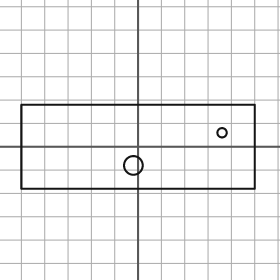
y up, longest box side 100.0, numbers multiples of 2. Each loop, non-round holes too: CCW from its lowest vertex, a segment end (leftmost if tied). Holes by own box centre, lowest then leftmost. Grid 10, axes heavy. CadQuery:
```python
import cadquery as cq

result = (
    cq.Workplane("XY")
    .moveTo(-50.0, -18.0)
    .lineTo(50.0, -18.0)
    .lineTo(50.0, 18.0)
    .lineTo(-50.0, 18.0)
    .close()
    .moveTo(-2.0, -8.0)
    .circle(4.0)
    .moveTo(36.0, 6.0)
    .circle(2.0)
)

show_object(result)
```